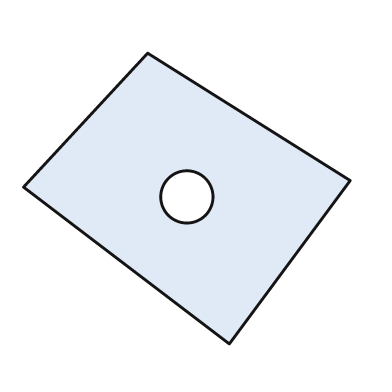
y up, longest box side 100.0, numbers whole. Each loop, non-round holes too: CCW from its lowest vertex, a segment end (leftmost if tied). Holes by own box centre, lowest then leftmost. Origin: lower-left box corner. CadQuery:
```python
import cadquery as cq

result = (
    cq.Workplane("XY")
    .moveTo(63.0, 0.0)
    .lineTo(100.0, 50.0)
    .lineTo(38.0, 89.0)
    .lineTo(0.0, 48.0)
    .close()
    .moveTo(50.0, 45.0)
    .circle(8.0)
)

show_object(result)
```